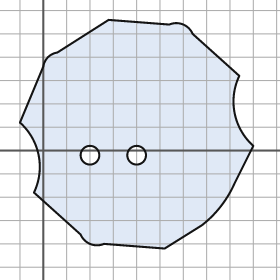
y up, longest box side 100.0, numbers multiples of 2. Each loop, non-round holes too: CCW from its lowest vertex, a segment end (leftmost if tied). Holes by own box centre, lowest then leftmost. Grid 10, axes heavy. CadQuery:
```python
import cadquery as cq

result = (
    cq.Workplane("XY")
    .moveTo(52.0, -42.0)
    .lineTo(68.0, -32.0)
    .threePointArc((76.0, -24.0), (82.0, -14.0))
    .lineTo(90.0, 2.0)
    .threePointArc((82.0, 16.0), (84.0, 32.0))
    .lineTo(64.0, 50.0)
    .threePointArc((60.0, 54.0), (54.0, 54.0))
    .lineTo(28.0, 56.0)
    .lineTo(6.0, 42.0)
    .threePointArc((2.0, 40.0), (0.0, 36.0))
    .lineTo(-10.0, 12.0)
    .threePointArc((-2.0, -2.0), (-4.0, -18.0))
    .lineTo(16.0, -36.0)
    .threePointArc((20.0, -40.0), (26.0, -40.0))
    .close()
    .moveTo(20.0, -2.0)
    .circle(4.0)
    .moveTo(40.0, -2.0)
    .circle(4.0)
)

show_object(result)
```